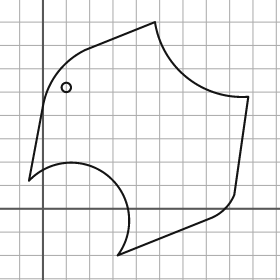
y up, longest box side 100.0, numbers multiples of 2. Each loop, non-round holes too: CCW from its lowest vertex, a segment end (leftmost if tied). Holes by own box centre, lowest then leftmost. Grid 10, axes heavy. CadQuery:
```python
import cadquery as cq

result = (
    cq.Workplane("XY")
    .moveTo(32.0, -20.0)
    .lineTo(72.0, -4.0)
    .threePointArc((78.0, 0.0), (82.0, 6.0))
    .lineTo(88.0, 48.0)
    .threePointArc((62.0, 56.0), (48.0, 80.0))
    .lineTo(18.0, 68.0)
    .threePointArc((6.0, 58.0), (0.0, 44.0))
    .lineTo(-6.0, 12.0)
    .threePointArc((28.0, 14.0), (32.0, -20.0))
    .close()
    .moveTo(10.0, 52.0)
    .circle(2.0)
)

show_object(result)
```